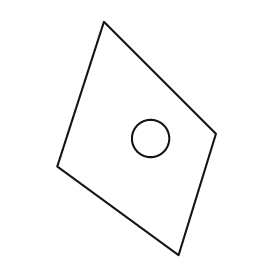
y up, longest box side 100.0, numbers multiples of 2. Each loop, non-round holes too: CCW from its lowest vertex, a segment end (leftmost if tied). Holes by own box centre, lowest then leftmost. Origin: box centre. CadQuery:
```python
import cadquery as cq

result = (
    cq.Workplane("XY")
    .moveTo(18.0, -50.0)
    .lineTo(34.0, 2.0)
    .lineTo(-14.0, 50.0)
    .lineTo(-34.0, -12.0)
    .close()
    .moveTo(6.0, 0.0)
    .circle(8.0)
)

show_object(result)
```